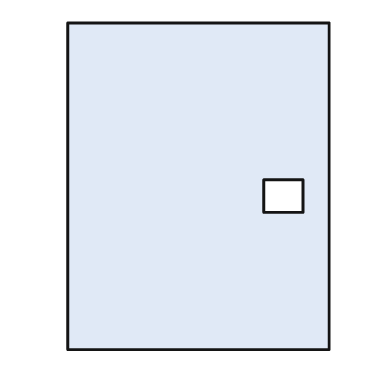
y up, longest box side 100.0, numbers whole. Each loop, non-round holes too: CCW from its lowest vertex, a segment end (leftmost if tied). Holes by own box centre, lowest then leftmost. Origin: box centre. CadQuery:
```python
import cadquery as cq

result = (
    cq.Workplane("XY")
    .moveTo(-40.0, -50.0)
    .lineTo(40.0, -50.0)
    .lineTo(40.0, 50.0)
    .lineTo(-40.0, 50.0)
    .close()
    .moveTo(20.0, -8.0)
    .lineTo(32.0, -8.0)
    .lineTo(32.0, 2.0)
    .lineTo(20.0, 2.0)
    .close()
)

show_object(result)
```